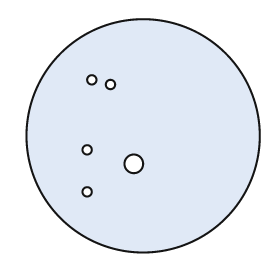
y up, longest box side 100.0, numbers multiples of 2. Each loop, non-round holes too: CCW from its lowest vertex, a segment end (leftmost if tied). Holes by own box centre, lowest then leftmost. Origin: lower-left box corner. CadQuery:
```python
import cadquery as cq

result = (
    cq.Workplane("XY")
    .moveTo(50.0, 50.0)
    .circle(50.0)
    .moveTo(26.0, 26.0)
    .circle(2.0)
    .moveTo(46.0, 38.0)
    .circle(4.0)
    .moveTo(26.0, 44.0)
    .circle(2.0)
    .moveTo(36.0, 72.0)
    .circle(2.0)
    .moveTo(28.0, 74.0)
    .circle(2.0)
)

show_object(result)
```